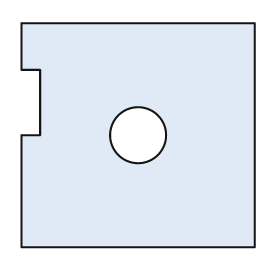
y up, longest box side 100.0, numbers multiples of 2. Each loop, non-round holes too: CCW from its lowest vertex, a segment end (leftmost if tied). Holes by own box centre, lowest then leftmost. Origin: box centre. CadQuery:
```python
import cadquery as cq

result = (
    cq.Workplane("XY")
    .moveTo(-50.0, -48.0)
    .lineTo(50.0, -48.0)
    .lineTo(50.0, 48.0)
    .lineTo(-50.0, 48.0)
    .lineTo(-50.0, 28.0)
    .lineTo(-42.0, 28.0)
    .lineTo(-42.0, 0.0)
    .lineTo(-50.0, 0.0)
    .close()
    .moveTo(0.0, 0.0)
    .circle(12.0)
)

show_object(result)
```